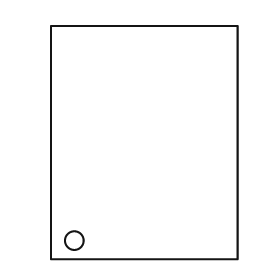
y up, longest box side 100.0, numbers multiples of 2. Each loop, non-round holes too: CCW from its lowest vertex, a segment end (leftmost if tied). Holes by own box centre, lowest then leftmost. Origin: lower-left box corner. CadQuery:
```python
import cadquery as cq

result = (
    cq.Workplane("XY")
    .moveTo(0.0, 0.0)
    .lineTo(80.0, 0.0)
    .lineTo(80.0, 100.0)
    .lineTo(0.0, 100.0)
    .close()
    .moveTo(10.0, 8.0)
    .circle(4.0)
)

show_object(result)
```